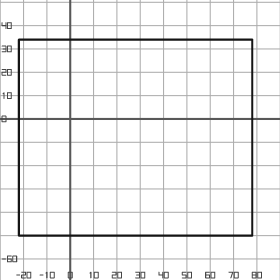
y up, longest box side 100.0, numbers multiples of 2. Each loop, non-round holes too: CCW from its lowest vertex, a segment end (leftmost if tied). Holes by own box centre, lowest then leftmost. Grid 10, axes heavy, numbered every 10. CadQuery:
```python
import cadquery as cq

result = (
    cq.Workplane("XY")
    .moveTo(-22.0, -50.0)
    .lineTo(78.0, -50.0)
    .lineTo(78.0, 34.0)
    .lineTo(-22.0, 34.0)
    .close()
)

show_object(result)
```